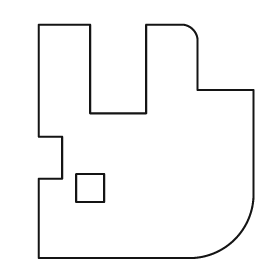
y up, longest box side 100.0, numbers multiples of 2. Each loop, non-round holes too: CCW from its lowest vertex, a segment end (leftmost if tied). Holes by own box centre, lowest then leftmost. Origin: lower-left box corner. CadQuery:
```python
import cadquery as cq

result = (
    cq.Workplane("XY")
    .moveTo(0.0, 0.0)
    .lineTo(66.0, 0.0)
    .threePointArc((84.0, 8.0), (92.0, 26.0))
    .lineTo(92.0, 72.0)
    .lineTo(68.0, 72.0)
    .lineTo(68.0, 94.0)
    .threePointArc((66.0, 98.0), (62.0, 100.0))
    .lineTo(46.0, 100.0)
    .lineTo(46.0, 62.0)
    .lineTo(22.0, 62.0)
    .lineTo(22.0, 100.0)
    .lineTo(0.0, 100.0)
    .lineTo(0.0, 52.0)
    .lineTo(10.0, 52.0)
    .lineTo(10.0, 34.0)
    .lineTo(0.0, 34.0)
    .close()
    .moveTo(16.0, 24.0)
    .lineTo(28.0, 24.0)
    .lineTo(28.0, 36.0)
    .lineTo(16.0, 36.0)
    .close()
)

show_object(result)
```